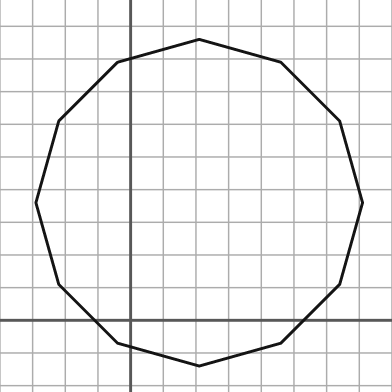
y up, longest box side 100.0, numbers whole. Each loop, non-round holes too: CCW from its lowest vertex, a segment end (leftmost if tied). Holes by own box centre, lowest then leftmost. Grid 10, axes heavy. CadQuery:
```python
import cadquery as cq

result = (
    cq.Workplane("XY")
    .moveTo(21.0, -14.0)
    .lineTo(46.0, -7.0)
    .lineTo(64.0, 11.0)
    .lineTo(71.0, 36.0)
    .lineTo(64.0, 61.0)
    .lineTo(46.0, 79.0)
    .lineTo(21.0, 86.0)
    .lineTo(-4.0, 79.0)
    .lineTo(-22.0, 61.0)
    .lineTo(-29.0, 36.0)
    .lineTo(-22.0, 11.0)
    .lineTo(-4.0, -7.0)
    .close()
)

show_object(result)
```